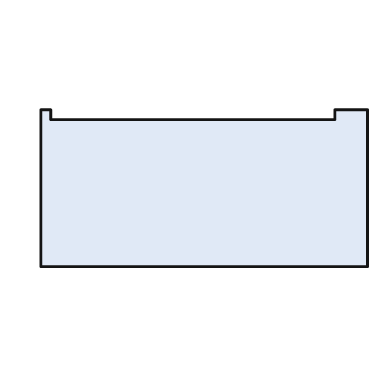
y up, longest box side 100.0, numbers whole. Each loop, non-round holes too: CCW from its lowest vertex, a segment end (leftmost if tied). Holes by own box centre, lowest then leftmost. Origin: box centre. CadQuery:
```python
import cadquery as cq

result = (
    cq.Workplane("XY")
    .moveTo(-50.0, -24.0)
    .lineTo(50.0, -24.0)
    .lineTo(50.0, 24.0)
    .lineTo(40.0, 24.0)
    .lineTo(40.0, 21.0)
    .lineTo(-47.0, 21.0)
    .lineTo(-47.0, 24.0)
    .lineTo(-50.0, 24.0)
    .close()
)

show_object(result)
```